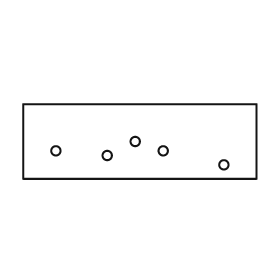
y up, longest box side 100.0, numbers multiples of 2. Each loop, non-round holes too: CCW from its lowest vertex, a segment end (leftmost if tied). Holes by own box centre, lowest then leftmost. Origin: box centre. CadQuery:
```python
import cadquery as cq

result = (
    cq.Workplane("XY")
    .moveTo(-50.0, -16.0)
    .lineTo(50.0, -16.0)
    .lineTo(50.0, 16.0)
    .lineTo(-50.0, 16.0)
    .close()
    .moveTo(36.0, -10.0)
    .circle(2.0)
    .moveTo(-14.0, -6.0)
    .circle(2.0)
    .moveTo(-36.0, -4.0)
    .circle(2.0)
    .moveTo(10.0, -4.0)
    .circle(2.0)
    .moveTo(-2.0, 0.0)
    .circle(2.0)
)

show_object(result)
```